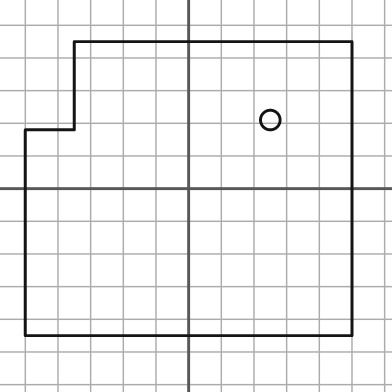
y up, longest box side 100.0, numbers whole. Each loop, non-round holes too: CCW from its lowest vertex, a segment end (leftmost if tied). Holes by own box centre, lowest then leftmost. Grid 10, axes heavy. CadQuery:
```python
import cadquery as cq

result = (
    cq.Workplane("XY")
    .moveTo(-50.0, -45.0)
    .lineTo(50.0, -45.0)
    .lineTo(50.0, 45.0)
    .lineTo(-35.0, 45.0)
    .lineTo(-35.0, 18.0)
    .lineTo(-50.0, 18.0)
    .close()
    .moveTo(25.0, 21.0)
    .circle(3.0)
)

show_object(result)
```